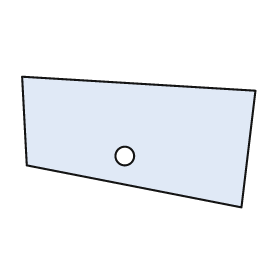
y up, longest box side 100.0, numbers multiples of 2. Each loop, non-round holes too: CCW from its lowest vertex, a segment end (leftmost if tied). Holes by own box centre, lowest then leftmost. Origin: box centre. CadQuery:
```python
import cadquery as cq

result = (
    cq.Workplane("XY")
    .moveTo(44.0, -28.0)
    .lineTo(50.0, 22.0)
    .lineTo(-50.0, 28.0)
    .lineTo(-48.0, -10.0)
    .close()
    .moveTo(-6.0, -6.0)
    .circle(4.0)
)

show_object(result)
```